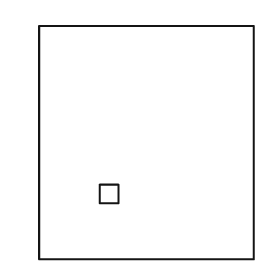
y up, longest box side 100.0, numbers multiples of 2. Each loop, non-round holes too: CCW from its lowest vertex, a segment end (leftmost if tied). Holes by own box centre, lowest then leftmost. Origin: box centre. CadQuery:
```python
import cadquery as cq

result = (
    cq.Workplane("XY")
    .moveTo(-46.0, -50.0)
    .lineTo(46.0, -50.0)
    .lineTo(46.0, 50.0)
    .lineTo(-46.0, 50.0)
    .close()
    .moveTo(-20.0, -26.0)
    .lineTo(-12.0, -26.0)
    .lineTo(-12.0, -18.0)
    .lineTo(-20.0, -18.0)
    .close()
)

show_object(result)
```